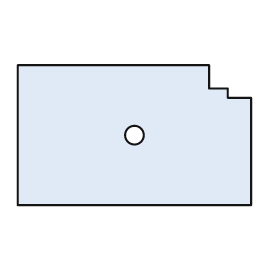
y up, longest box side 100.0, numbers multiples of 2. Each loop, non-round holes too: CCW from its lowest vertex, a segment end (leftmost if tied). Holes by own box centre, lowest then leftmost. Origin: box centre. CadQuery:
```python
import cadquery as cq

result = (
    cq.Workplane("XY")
    .moveTo(-50.0, -30.0)
    .lineTo(50.0, -30.0)
    .lineTo(50.0, 16.0)
    .lineTo(40.0, 16.0)
    .lineTo(40.0, 20.0)
    .lineTo(32.0, 20.0)
    .lineTo(32.0, 30.0)
    .lineTo(-50.0, 30.0)
    .close()
    .moveTo(0.0, 0.0)
    .circle(4.0)
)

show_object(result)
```